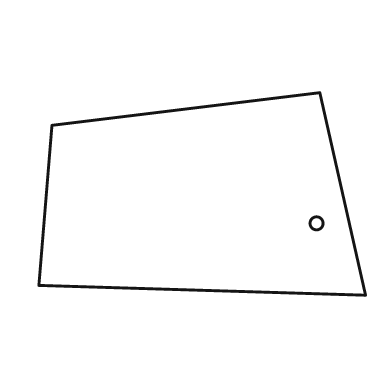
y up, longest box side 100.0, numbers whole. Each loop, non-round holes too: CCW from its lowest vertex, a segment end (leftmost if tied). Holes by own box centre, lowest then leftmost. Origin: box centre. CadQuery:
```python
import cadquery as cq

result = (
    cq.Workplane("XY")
    .moveTo(50.0, -31.0)
    .lineTo(36.0, 31.0)
    .lineTo(-46.0, 21.0)
    .lineTo(-50.0, -28.0)
    .close()
    .moveTo(35.0, -9.0)
    .circle(2.0)
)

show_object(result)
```